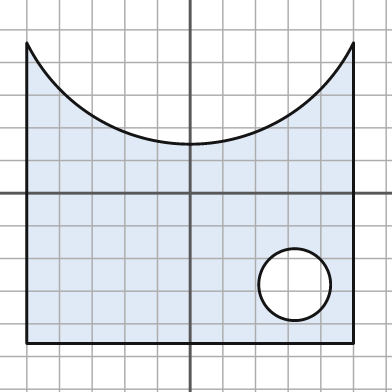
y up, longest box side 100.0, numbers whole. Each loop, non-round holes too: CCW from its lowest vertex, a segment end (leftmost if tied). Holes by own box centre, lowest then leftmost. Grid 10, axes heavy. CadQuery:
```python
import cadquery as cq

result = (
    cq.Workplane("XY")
    .moveTo(-50.0, -46.0)
    .lineTo(50.0, -46.0)
    .lineTo(50.0, 46.0)
    .threePointArc((0.0, 15.0), (-50.0, 46.0))
    .close()
    .moveTo(32.0, -28.0)
    .circle(11.0)
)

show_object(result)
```